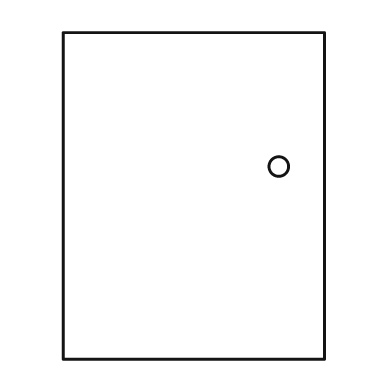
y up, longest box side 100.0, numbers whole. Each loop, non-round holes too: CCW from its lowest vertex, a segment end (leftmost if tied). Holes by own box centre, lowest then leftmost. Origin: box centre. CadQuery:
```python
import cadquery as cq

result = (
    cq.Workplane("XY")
    .moveTo(-40.0, -50.0)
    .lineTo(40.0, -50.0)
    .lineTo(40.0, 50.0)
    .lineTo(-40.0, 50.0)
    .close()
    .moveTo(26.0, 9.0)
    .circle(3.0)
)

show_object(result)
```